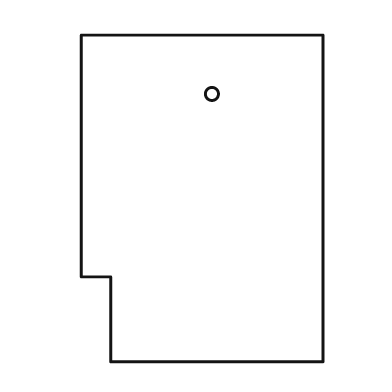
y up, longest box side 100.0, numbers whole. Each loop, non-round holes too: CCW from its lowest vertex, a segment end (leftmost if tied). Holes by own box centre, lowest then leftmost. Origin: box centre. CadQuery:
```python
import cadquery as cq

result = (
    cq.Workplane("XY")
    .moveTo(-28.0, -50.0)
    .lineTo(37.0, -50.0)
    .lineTo(37.0, 50.0)
    .lineTo(-37.0, 50.0)
    .lineTo(-37.0, -24.0)
    .lineTo(-28.0, -24.0)
    .close()
    .moveTo(3.0, 32.0)
    .circle(2.0)
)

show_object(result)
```